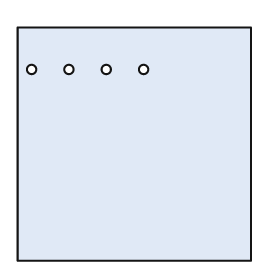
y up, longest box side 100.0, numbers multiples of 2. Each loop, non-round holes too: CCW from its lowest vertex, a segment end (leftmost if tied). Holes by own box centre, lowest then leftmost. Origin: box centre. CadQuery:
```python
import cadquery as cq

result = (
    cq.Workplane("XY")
    .moveTo(-50.0, -50.0)
    .lineTo(50.0, -50.0)
    .lineTo(50.0, 50.0)
    .lineTo(-50.0, 50.0)
    .close()
    .moveTo(-44.0, 32.0)
    .circle(2.0)
    .moveTo(-28.0, 32.0)
    .circle(2.0)
    .moveTo(-12.0, 32.0)
    .circle(2.0)
    .moveTo(4.0, 32.0)
    .circle(2.0)
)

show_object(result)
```